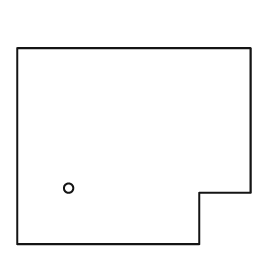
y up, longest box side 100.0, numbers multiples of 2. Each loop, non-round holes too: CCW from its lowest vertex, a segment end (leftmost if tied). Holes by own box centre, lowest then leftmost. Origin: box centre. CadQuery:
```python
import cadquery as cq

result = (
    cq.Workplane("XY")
    .moveTo(-50.0, -42.0)
    .lineTo(28.0, -42.0)
    .lineTo(28.0, -20.0)
    .lineTo(50.0, -20.0)
    .lineTo(50.0, 42.0)
    .lineTo(-50.0, 42.0)
    .close()
    .moveTo(-28.0, -18.0)
    .circle(2.0)
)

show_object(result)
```